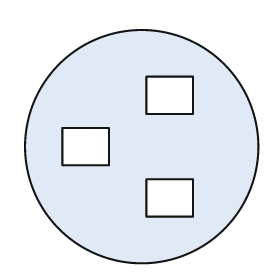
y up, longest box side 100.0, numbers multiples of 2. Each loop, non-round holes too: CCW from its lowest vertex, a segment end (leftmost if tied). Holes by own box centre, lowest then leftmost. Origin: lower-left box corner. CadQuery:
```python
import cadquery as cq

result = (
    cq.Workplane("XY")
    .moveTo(50.0, 50.0)
    .circle(50.0)
    .moveTo(52.0, 20.0)
    .lineTo(72.0, 20.0)
    .lineTo(72.0, 36.0)
    .lineTo(52.0, 36.0)
    .close()
    .moveTo(16.0, 42.0)
    .lineTo(36.0, 42.0)
    .lineTo(36.0, 58.0)
    .lineTo(16.0, 58.0)
    .close()
    .moveTo(52.0, 64.0)
    .lineTo(72.0, 64.0)
    .lineTo(72.0, 80.0)
    .lineTo(52.0, 80.0)
    .close()
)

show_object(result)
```